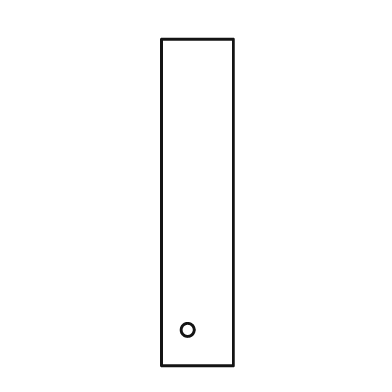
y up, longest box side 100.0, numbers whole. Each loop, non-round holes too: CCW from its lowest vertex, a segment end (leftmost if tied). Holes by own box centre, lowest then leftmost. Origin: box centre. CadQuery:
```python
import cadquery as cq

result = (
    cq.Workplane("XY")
    .moveTo(-11.0, -50.0)
    .lineTo(11.0, -50.0)
    .lineTo(11.0, 50.0)
    .lineTo(-11.0, 50.0)
    .close()
    .moveTo(-3.0, -39.0)
    .circle(2.0)
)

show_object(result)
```